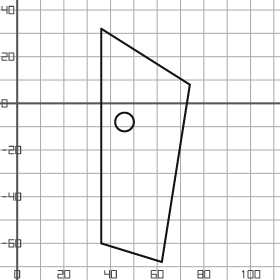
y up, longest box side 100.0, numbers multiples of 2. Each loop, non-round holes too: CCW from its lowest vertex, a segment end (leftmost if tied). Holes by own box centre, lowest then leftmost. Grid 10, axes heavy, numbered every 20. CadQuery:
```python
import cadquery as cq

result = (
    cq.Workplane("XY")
    .moveTo(62.0, -68.0)
    .lineTo(74.0, 8.0)
    .lineTo(36.0, 32.0)
    .lineTo(36.0, -60.0)
    .close()
    .moveTo(46.0, -8.0)
    .circle(4.0)
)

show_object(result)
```